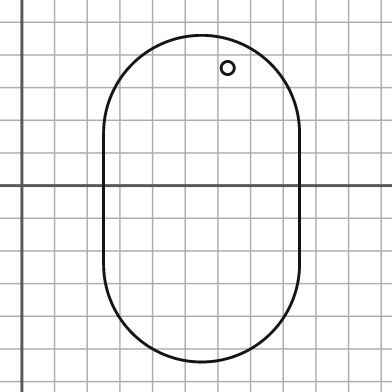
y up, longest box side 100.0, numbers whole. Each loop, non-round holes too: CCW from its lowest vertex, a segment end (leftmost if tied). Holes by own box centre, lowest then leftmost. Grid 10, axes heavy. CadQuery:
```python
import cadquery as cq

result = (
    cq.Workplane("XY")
    .moveTo(25.0, -24.0)
    .threePointArc((55.0, -54.0), (85.0, -24.0))
    .lineTo(85.0, 16.0)
    .threePointArc((55.0, 46.0), (25.0, 16.0))
    .close()
    .moveTo(63.0, 36.0)
    .circle(2.0)
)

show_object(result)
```